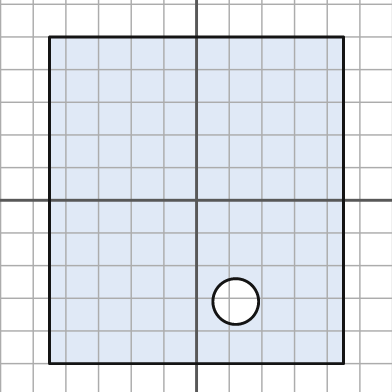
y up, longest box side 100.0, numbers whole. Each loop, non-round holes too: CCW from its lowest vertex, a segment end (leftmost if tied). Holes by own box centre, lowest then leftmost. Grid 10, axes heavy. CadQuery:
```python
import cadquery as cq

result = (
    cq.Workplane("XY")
    .moveTo(-45.0, -50.0)
    .lineTo(45.0, -50.0)
    .lineTo(45.0, 50.0)
    .lineTo(-45.0, 50.0)
    .close()
    .moveTo(12.0, -31.0)
    .circle(7.0)
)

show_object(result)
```